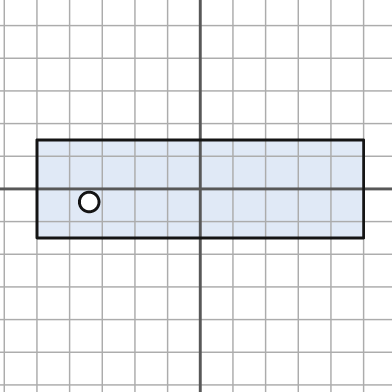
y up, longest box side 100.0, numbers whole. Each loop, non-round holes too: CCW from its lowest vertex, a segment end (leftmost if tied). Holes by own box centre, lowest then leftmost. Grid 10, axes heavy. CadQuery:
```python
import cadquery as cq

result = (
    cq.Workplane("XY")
    .moveTo(-50.0, -15.0)
    .lineTo(50.0, -15.0)
    .lineTo(50.0, 15.0)
    .lineTo(-50.0, 15.0)
    .close()
    .moveTo(-34.0, -4.0)
    .circle(3.0)
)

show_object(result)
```